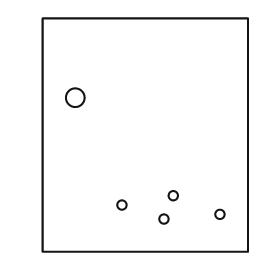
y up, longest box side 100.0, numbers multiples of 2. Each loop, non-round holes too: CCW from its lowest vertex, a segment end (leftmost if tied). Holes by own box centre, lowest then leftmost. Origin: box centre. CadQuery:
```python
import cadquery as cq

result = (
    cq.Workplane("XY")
    .moveTo(-44.0, -50.0)
    .lineTo(44.0, -50.0)
    .lineTo(44.0, 50.0)
    .lineTo(-44.0, 50.0)
    .close()
    .moveTo(8.0, -36.0)
    .circle(2.0)
    .moveTo(32.0, -34.0)
    .circle(2.0)
    .moveTo(-10.0, -30.0)
    .circle(2.0)
    .moveTo(12.0, -26.0)
    .circle(2.0)
    .moveTo(-30.0, 16.0)
    .circle(4.0)
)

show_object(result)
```